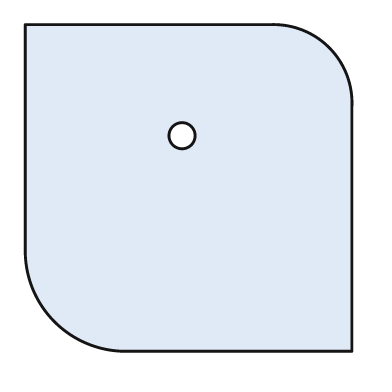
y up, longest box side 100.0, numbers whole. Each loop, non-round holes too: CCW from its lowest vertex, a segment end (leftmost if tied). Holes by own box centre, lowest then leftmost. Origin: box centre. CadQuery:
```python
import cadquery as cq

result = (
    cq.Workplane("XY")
    .moveTo(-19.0, -50.0)
    .lineTo(50.0, -50.0)
    .lineTo(50.0, 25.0)
    .threePointArc((43.0, 43.0), (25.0, 50.0))
    .lineTo(-50.0, 50.0)
    .lineTo(-50.0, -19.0)
    .threePointArc((-41.0, -41.0), (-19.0, -50.0))
    .close()
    .moveTo(-2.0, 16.0)
    .circle(4.0)
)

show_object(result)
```